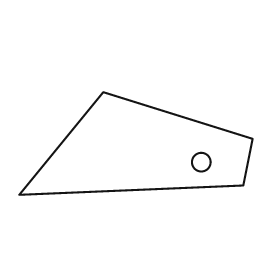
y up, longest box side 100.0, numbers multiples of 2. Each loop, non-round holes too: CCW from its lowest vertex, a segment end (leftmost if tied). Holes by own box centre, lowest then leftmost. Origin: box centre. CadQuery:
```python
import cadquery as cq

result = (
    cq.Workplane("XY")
    .moveTo(-50.0, -22.0)
    .lineTo(46.0, -18.0)
    .lineTo(50.0, 2.0)
    .lineTo(-14.0, 22.0)
    .close()
    .moveTo(28.0, -8.0)
    .circle(4.0)
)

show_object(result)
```